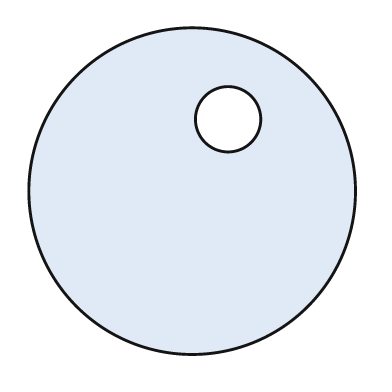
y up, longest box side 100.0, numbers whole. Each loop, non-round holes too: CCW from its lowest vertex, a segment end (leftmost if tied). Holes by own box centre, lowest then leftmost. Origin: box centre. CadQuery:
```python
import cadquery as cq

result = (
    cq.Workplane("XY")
    .moveTo(0.0, 0.0)
    .circle(50.0)
    .moveTo(11.0, 22.0)
    .circle(10.0)
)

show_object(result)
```